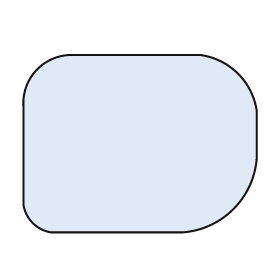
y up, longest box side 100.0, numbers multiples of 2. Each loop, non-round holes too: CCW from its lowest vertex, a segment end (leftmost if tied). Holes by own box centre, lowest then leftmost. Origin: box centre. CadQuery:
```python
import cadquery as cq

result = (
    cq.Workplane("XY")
    .moveTo(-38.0, -38.0)
    .lineTo(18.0, -38.0)
    .threePointArc((40.0, -28.0), (50.0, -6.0))
    .lineTo(50.0, 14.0)
    .threePointArc((42.0, 30.0), (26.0, 38.0))
    .lineTo(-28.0, 38.0)
    .threePointArc((-44.0, 32.0), (-50.0, 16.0))
    .lineTo(-50.0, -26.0)
    .threePointArc((-46.0, -34.0), (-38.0, -38.0))
    .close()
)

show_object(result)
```